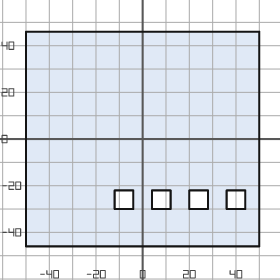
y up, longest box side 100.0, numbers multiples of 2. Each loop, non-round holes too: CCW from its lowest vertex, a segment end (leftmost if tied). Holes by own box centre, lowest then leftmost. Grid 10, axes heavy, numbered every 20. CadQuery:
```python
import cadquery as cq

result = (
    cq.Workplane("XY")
    .moveTo(-50.0, -46.0)
    .lineTo(50.0, -46.0)
    .lineTo(50.0, 46.0)
    .lineTo(-50.0, 46.0)
    .close()
    .moveTo(-12.0, -30.0)
    .lineTo(-4.0, -30.0)
    .lineTo(-4.0, -22.0)
    .lineTo(-12.0, -22.0)
    .close()
    .moveTo(4.0, -30.0)
    .lineTo(12.0, -30.0)
    .lineTo(12.0, -22.0)
    .lineTo(4.0, -22.0)
    .close()
    .moveTo(20.0, -30.0)
    .lineTo(28.0, -30.0)
    .lineTo(28.0, -22.0)
    .lineTo(20.0, -22.0)
    .close()
    .moveTo(36.0, -30.0)
    .lineTo(44.0, -30.0)
    .lineTo(44.0, -22.0)
    .lineTo(36.0, -22.0)
    .close()
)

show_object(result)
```